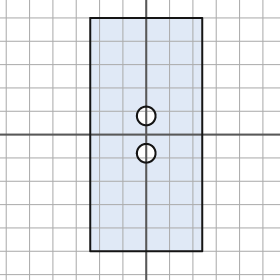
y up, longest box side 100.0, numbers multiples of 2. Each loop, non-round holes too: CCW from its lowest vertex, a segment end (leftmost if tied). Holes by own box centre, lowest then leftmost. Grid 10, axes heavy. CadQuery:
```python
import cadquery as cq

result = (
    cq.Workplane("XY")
    .moveTo(-24.0, -50.0)
    .lineTo(24.0, -50.0)
    .lineTo(24.0, 50.0)
    .lineTo(-24.0, 50.0)
    .close()
    .moveTo(0.0, -8.0)
    .circle(4.0)
    .moveTo(0.0, 8.0)
    .circle(4.0)
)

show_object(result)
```